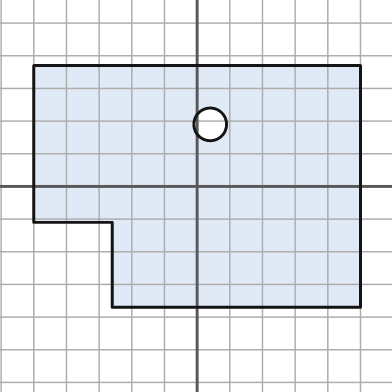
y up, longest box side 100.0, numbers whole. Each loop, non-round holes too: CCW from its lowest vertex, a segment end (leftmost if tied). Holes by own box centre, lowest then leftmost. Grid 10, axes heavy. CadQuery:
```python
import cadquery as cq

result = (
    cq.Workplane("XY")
    .moveTo(-26.0, -37.0)
    .lineTo(50.0, -37.0)
    .lineTo(50.0, 37.0)
    .lineTo(-50.0, 37.0)
    .lineTo(-50.0, -11.0)
    .lineTo(-26.0, -11.0)
    .close()
    .moveTo(4.0, 19.0)
    .circle(5.0)
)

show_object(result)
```